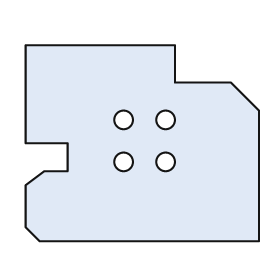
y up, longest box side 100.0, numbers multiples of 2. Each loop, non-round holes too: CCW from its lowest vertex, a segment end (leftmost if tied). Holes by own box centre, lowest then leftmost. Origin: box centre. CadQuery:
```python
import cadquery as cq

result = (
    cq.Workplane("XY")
    .moveTo(-44.0, -42.0)
    .lineTo(50.0, -42.0)
    .lineTo(50.0, 14.0)
    .lineTo(38.0, 26.0)
    .lineTo(14.0, 26.0)
    .lineTo(14.0, 42.0)
    .lineTo(-50.0, 42.0)
    .lineTo(-50.0, 0.0)
    .lineTo(-32.0, 0.0)
    .lineTo(-32.0, -12.0)
    .lineTo(-42.0, -12.0)
    .lineTo(-50.0, -18.0)
    .lineTo(-50.0, -36.0)
    .close()
    .moveTo(-8.0, -8.0)
    .circle(4.0)
    .moveTo(10.0, -8.0)
    .circle(4.0)
    .moveTo(-8.0, 10.0)
    .circle(4.0)
    .moveTo(10.0, 10.0)
    .circle(4.0)
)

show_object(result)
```